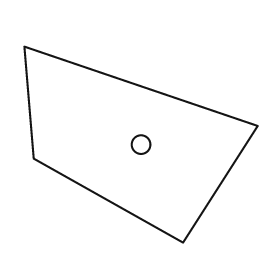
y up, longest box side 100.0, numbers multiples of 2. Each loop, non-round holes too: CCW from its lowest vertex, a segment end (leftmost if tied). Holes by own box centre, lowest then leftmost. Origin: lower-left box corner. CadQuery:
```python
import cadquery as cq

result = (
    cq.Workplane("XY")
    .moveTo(68.0, 0.0)
    .lineTo(100.0, 50.0)
    .lineTo(0.0, 84.0)
    .lineTo(4.0, 36.0)
    .close()
    .moveTo(50.0, 42.0)
    .circle(4.0)
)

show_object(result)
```